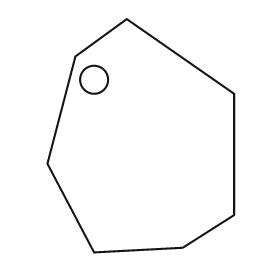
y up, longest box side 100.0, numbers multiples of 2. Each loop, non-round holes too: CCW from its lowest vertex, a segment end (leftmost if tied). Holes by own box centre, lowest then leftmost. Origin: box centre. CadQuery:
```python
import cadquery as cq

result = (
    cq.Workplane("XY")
    .moveTo(-20.0, -50.0)
    .lineTo(18.0, -48.0)
    .lineTo(40.0, -34.0)
    .lineTo(40.0, 18.0)
    .lineTo(-6.0, 50.0)
    .lineTo(-28.0, 34.0)
    .lineTo(-40.0, -12.0)
    .close()
    .moveTo(-20.0, 24.0)
    .circle(6.0)
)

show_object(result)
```